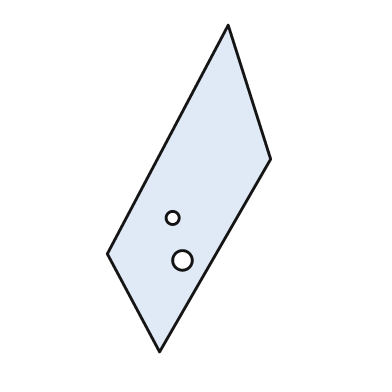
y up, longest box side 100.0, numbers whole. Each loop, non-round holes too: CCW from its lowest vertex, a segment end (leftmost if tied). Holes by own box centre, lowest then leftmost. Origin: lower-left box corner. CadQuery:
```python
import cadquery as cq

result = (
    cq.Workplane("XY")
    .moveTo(16.0, 0.0)
    .lineTo(50.0, 59.0)
    .lineTo(37.0, 100.0)
    .lineTo(0.0, 30.0)
    .close()
    .moveTo(23.0, 28.0)
    .circle(3.0)
    .moveTo(20.0, 41.0)
    .circle(2.0)
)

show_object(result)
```